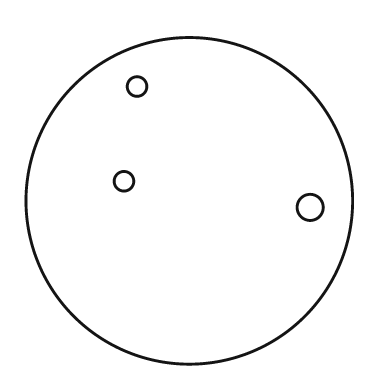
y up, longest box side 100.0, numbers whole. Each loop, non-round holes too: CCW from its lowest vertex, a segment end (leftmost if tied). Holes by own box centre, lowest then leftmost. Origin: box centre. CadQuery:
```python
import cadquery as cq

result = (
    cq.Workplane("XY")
    .moveTo(0.0, 0.0)
    .circle(50.0)
    .moveTo(37.0, -2.0)
    .circle(4.0)
    .moveTo(-20.0, 6.0)
    .circle(3.0)
    .moveTo(-16.0, 35.0)
    .circle(3.0)
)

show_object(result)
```